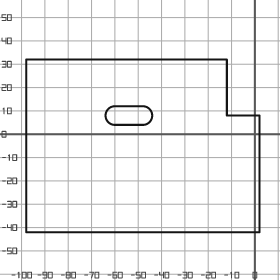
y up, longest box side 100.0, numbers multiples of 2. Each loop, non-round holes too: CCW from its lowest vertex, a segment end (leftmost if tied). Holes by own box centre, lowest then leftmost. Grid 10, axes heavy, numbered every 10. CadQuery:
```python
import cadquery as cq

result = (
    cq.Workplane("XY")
    .moveTo(-98.0, -42.0)
    .lineTo(2.0, -42.0)
    .lineTo(2.0, 8.0)
    .lineTo(-12.0, 8.0)
    .lineTo(-12.0, 32.0)
    .lineTo(-98.0, 32.0)
    .close()
    .moveTo(-60.0, 4.0)
    .lineTo(-48.0, 4.0)
    .threePointArc((-44.0, 8.0), (-48.0, 12.0))
    .lineTo(-60.0, 12.0)
    .threePointArc((-64.0, 8.0), (-60.0, 4.0))
    .close()
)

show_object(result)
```